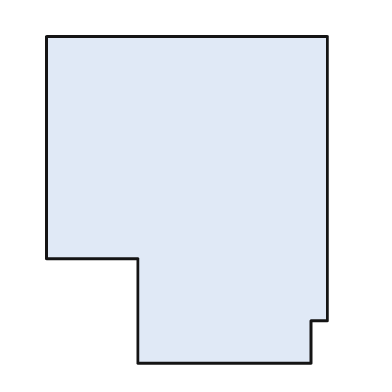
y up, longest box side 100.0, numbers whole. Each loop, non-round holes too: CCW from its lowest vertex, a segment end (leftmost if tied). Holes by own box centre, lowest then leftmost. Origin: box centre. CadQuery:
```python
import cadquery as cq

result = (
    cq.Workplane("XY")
    .moveTo(-15.0, -50.0)
    .lineTo(38.0, -50.0)
    .lineTo(38.0, -37.0)
    .lineTo(43.0, -37.0)
    .lineTo(43.0, 50.0)
    .lineTo(-43.0, 50.0)
    .lineTo(-43.0, -18.0)
    .lineTo(-15.0, -18.0)
    .close()
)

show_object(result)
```